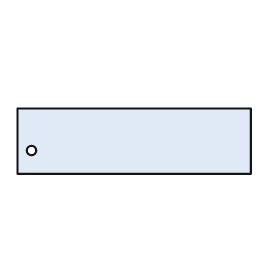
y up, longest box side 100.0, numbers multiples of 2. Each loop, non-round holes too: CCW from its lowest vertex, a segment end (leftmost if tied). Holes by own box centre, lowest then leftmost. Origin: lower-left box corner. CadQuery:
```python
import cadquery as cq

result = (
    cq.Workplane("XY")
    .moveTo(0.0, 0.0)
    .lineTo(100.0, 0.0)
    .lineTo(100.0, 28.0)
    .lineTo(0.0, 28.0)
    .close()
    .moveTo(6.0, 10.0)
    .circle(2.0)
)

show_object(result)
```